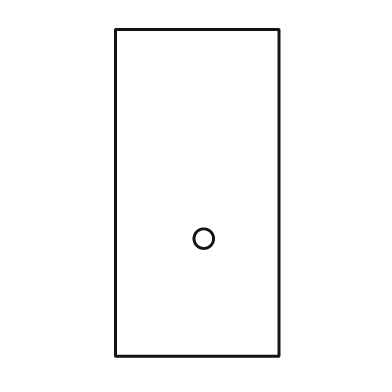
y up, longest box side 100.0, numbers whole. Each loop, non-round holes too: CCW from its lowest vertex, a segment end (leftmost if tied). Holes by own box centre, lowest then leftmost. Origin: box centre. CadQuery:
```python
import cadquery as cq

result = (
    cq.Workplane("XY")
    .moveTo(-25.0, -50.0)
    .lineTo(25.0, -50.0)
    .lineTo(25.0, 50.0)
    .lineTo(-25.0, 50.0)
    .close()
    .moveTo(2.0, -14.0)
    .circle(3.0)
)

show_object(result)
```